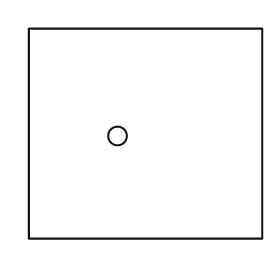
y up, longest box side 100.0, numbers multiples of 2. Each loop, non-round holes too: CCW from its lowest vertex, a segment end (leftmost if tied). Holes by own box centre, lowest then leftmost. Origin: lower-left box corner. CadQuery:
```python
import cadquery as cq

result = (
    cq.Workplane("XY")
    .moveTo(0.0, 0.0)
    .lineTo(100.0, 0.0)
    .lineTo(100.0, 90.0)
    .lineTo(0.0, 90.0)
    .close()
    .moveTo(38.0, 44.0)
    .circle(4.0)
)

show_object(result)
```